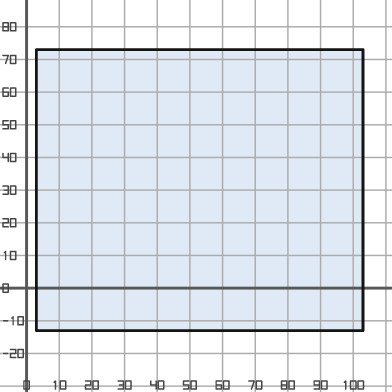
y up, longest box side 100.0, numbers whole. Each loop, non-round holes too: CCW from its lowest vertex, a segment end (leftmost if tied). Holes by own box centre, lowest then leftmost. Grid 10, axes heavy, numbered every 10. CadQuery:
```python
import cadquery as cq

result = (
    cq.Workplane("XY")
    .moveTo(3.0, -13.0)
    .lineTo(103.0, -13.0)
    .lineTo(103.0, 73.0)
    .lineTo(3.0, 73.0)
    .close()
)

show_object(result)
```